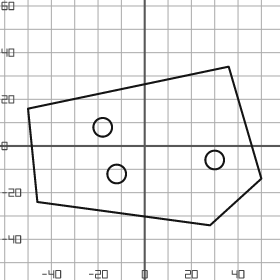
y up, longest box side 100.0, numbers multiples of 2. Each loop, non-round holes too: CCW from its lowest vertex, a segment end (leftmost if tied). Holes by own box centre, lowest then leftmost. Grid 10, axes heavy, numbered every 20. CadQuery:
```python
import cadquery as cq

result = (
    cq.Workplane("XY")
    .moveTo(28.0, -34.0)
    .lineTo(50.0, -14.0)
    .lineTo(36.0, 34.0)
    .lineTo(-50.0, 16.0)
    .lineTo(-46.0, -24.0)
    .close()
    .moveTo(-12.0, -12.0)
    .circle(4.0)
    .moveTo(30.0, -6.0)
    .circle(4.0)
    .moveTo(-18.0, 8.0)
    .circle(4.0)
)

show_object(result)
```